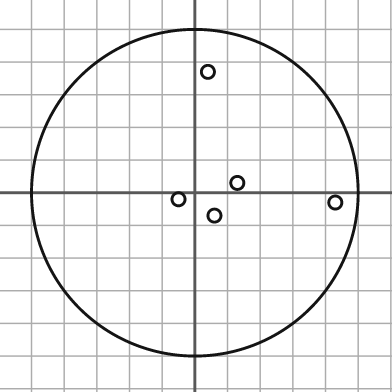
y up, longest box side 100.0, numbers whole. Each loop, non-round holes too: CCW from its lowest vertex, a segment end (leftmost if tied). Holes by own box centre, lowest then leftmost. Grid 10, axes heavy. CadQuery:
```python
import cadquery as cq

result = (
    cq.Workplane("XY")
    .moveTo(0.0, 0.0)
    .circle(50.0)
    .moveTo(6.0, -7.0)
    .circle(2.0)
    .moveTo(43.0, -3.0)
    .circle(2.0)
    .moveTo(-5.0, -2.0)
    .circle(2.0)
    .moveTo(13.0, 3.0)
    .circle(2.0)
    .moveTo(4.0, 37.0)
    .circle(2.0)
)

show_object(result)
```